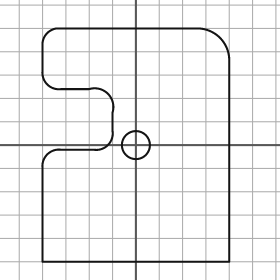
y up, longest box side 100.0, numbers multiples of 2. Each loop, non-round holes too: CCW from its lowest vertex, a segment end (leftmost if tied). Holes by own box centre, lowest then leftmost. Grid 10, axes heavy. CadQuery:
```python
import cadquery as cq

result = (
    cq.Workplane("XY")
    .moveTo(-40.0, -50.0)
    .lineTo(40.0, -50.0)
    .lineTo(40.0, 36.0)
    .threePointArc((36.0, 46.0), (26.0, 50.0))
    .lineTo(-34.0, 50.0)
    .threePointArc((-38.0, 48.0), (-40.0, 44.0))
    .lineTo(-40.0, 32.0)
    .threePointArc((-38.0, 26.0), (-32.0, 24.0))
    .lineTo(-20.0, 24.0)
    .threePointArc((-12.0, 22.0), (-10.0, 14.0))
    .lineTo(-10.0, 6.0)
    .threePointArc((-12.0, 0.0), (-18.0, -2.0))
    .lineTo(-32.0, -2.0)
    .threePointArc((-38.0, -4.0), (-40.0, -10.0))
    .close()
    .moveTo(0.0, 0.0)
    .circle(6.0)
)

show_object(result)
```